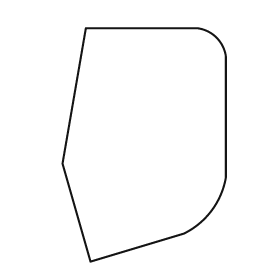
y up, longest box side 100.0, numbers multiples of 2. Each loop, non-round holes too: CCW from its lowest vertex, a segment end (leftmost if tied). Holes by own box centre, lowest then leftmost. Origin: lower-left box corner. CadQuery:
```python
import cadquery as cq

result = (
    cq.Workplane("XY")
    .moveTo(12.0, 0.0)
    .lineTo(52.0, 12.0)
    .threePointArc((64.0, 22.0), (70.0, 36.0))
    .lineTo(70.0, 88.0)
    .threePointArc((66.0, 96.0), (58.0, 100.0))
    .lineTo(10.0, 100.0)
    .lineTo(0.0, 42.0)
    .close()
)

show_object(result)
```